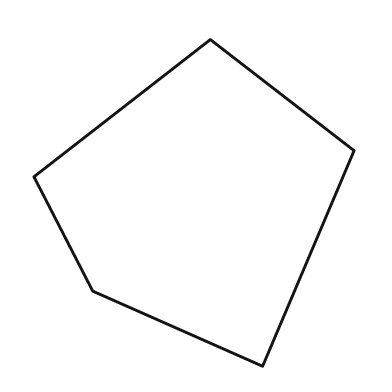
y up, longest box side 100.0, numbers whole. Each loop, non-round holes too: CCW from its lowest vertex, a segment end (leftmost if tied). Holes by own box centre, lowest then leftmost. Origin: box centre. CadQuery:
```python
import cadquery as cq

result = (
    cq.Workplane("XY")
    .moveTo(21.0, -50.0)
    .lineTo(49.0, 16.0)
    .lineTo(5.0, 50.0)
    .lineTo(-49.0, 8.0)
    .lineTo(-31.0, -27.0)
    .close()
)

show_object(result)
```